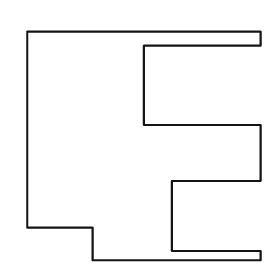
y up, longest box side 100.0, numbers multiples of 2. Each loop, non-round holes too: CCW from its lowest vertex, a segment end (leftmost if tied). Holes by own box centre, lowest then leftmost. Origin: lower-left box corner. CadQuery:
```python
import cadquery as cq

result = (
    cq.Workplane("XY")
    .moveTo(28.0, 0.0)
    .lineTo(100.0, 0.0)
    .lineTo(100.0, 4.0)
    .lineTo(62.0, 4.0)
    .lineTo(62.0, 34.0)
    .lineTo(100.0, 34.0)
    .lineTo(100.0, 58.0)
    .lineTo(50.0, 58.0)
    .lineTo(50.0, 92.0)
    .lineTo(100.0, 92.0)
    .lineTo(100.0, 98.0)
    .lineTo(0.0, 98.0)
    .lineTo(0.0, 14.0)
    .lineTo(28.0, 14.0)
    .close()
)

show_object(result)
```